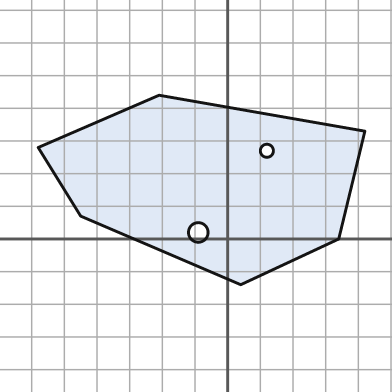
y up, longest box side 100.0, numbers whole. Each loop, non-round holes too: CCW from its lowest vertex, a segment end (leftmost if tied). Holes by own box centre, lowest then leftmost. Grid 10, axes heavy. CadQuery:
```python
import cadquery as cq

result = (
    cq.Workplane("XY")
    .moveTo(4.0, -14.0)
    .lineTo(34.0, 0.0)
    .lineTo(42.0, 33.0)
    .lineTo(-21.0, 44.0)
    .lineTo(-58.0, 28.0)
    .lineTo(-45.0, 7.0)
    .close()
    .moveTo(-9.0, 2.0)
    .circle(3.0)
    .moveTo(12.0, 27.0)
    .circle(2.0)
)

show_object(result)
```